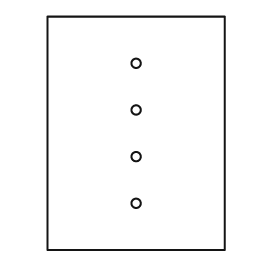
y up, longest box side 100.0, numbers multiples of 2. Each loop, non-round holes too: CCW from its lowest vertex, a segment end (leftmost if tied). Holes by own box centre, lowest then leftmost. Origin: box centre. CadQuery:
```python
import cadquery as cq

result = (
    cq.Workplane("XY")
    .moveTo(-38.0, -50.0)
    .lineTo(38.0, -50.0)
    .lineTo(38.0, 50.0)
    .lineTo(-38.0, 50.0)
    .close()
    .moveTo(0.0, -30.0)
    .circle(2.0)
    .moveTo(0.0, -10.0)
    .circle(2.0)
    .moveTo(0.0, 10.0)
    .circle(2.0)
    .moveTo(0.0, 30.0)
    .circle(2.0)
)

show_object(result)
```